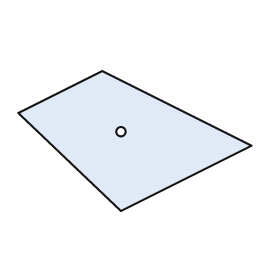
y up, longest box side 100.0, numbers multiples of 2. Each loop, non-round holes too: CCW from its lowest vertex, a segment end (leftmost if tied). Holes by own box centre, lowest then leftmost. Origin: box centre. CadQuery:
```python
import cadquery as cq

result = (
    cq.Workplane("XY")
    .moveTo(-6.0, -30.0)
    .lineTo(50.0, -2.0)
    .lineTo(-14.0, 30.0)
    .lineTo(-50.0, 12.0)
    .close()
    .moveTo(-6.0, 4.0)
    .circle(2.0)
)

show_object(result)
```